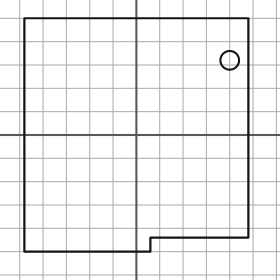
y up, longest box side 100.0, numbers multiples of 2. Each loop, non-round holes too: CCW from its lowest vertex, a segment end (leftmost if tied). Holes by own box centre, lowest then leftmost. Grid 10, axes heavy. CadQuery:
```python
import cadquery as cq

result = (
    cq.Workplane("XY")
    .moveTo(-48.0, -50.0)
    .lineTo(6.0, -50.0)
    .lineTo(6.0, -44.0)
    .lineTo(48.0, -44.0)
    .lineTo(48.0, 50.0)
    .lineTo(-48.0, 50.0)
    .close()
    .moveTo(40.0, 32.0)
    .circle(4.0)
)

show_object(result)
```